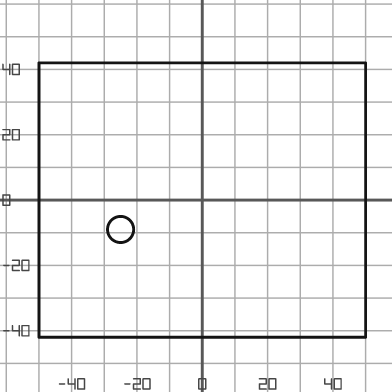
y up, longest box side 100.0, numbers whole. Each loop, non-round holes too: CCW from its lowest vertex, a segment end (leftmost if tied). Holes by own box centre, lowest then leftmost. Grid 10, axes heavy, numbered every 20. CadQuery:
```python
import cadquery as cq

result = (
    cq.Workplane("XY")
    .moveTo(-50.0, -42.0)
    .lineTo(50.0, -42.0)
    .lineTo(50.0, 42.0)
    .lineTo(-50.0, 42.0)
    .close()
    .moveTo(-25.0, -9.0)
    .circle(4.0)
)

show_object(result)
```